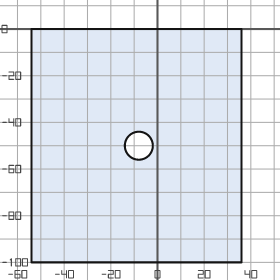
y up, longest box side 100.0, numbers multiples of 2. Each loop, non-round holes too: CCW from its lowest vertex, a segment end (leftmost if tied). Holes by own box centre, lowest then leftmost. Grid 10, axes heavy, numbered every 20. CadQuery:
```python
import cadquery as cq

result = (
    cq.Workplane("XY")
    .moveTo(-54.0, -100.0)
    .lineTo(36.0, -100.0)
    .lineTo(36.0, 0.0)
    .lineTo(-54.0, 0.0)
    .close()
    .moveTo(-8.0, -50.0)
    .circle(6.0)
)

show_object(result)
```